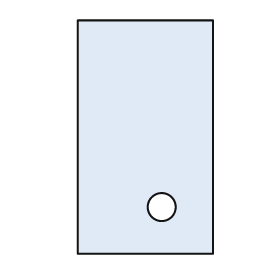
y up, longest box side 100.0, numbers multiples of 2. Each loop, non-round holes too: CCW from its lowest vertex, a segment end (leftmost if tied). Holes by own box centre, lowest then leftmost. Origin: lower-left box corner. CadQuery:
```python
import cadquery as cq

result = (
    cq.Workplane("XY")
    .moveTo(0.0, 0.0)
    .lineTo(58.0, 0.0)
    .lineTo(58.0, 100.0)
    .lineTo(0.0, 100.0)
    .close()
    .moveTo(36.0, 20.0)
    .circle(6.0)
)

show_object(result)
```